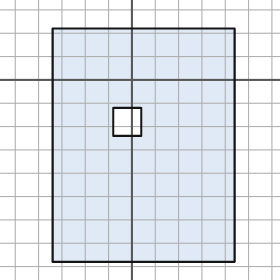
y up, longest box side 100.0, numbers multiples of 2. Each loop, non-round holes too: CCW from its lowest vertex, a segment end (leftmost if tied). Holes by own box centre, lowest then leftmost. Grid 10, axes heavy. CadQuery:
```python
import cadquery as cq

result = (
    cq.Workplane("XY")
    .moveTo(-34.0, -78.0)
    .lineTo(44.0, -78.0)
    .lineTo(44.0, 22.0)
    .lineTo(-34.0, 22.0)
    .close()
    .moveTo(-8.0, -24.0)
    .lineTo(4.0, -24.0)
    .lineTo(4.0, -12.0)
    .lineTo(-8.0, -12.0)
    .close()
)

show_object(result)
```